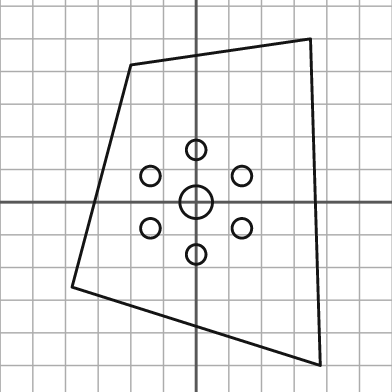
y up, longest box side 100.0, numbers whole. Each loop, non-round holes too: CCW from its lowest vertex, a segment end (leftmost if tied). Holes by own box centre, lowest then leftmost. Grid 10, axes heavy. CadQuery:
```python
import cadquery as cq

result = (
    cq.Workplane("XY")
    .moveTo(38.0, -50.0)
    .lineTo(35.0, 50.0)
    .lineTo(-20.0, 42.0)
    .lineTo(-38.0, -26.0)
    .close()
    .moveTo(0.0, -16.0)
    .circle(3.0)
    .moveTo(-14.0, -8.0)
    .circle(3.0)
    .moveTo(14.0, -8.0)
    .circle(3.0)
    .moveTo(0.0, 0.0)
    .circle(5.0)
    .moveTo(-14.0, 8.0)
    .circle(3.0)
    .moveTo(14.0, 8.0)
    .circle(3.0)
    .moveTo(0.0, 16.0)
    .circle(3.0)
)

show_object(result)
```